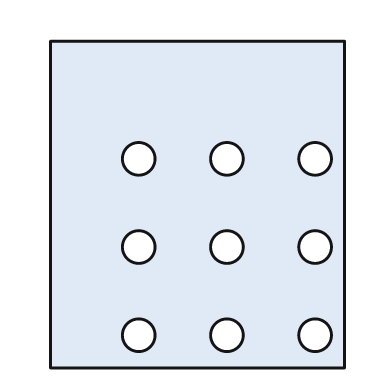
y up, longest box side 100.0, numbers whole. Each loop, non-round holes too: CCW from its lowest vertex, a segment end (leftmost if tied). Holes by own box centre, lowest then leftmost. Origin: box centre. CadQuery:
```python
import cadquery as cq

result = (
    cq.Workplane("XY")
    .moveTo(-45.0, -50.0)
    .lineTo(45.0, -50.0)
    .lineTo(45.0, 50.0)
    .lineTo(-45.0, 50.0)
    .close()
    .moveTo(-18.0, -40.0)
    .circle(5.0)
    .moveTo(9.0, -40.0)
    .circle(5.0)
    .moveTo(36.0, -40.0)
    .circle(5.0)
    .moveTo(-18.0, -13.0)
    .circle(5.0)
    .moveTo(9.0, -13.0)
    .circle(5.0)
    .moveTo(36.0, -13.0)
    .circle(5.0)
    .moveTo(-18.0, 14.0)
    .circle(5.0)
    .moveTo(9.0, 14.0)
    .circle(5.0)
    .moveTo(36.0, 14.0)
    .circle(5.0)
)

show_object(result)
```